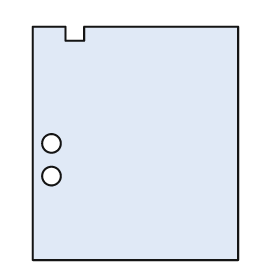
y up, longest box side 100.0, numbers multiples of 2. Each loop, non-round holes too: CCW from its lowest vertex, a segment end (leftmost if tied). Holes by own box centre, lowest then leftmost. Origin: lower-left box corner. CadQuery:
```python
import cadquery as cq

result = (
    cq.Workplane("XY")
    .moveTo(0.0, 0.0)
    .lineTo(88.0, 0.0)
    .lineTo(88.0, 100.0)
    .lineTo(22.0, 100.0)
    .lineTo(22.0, 94.0)
    .lineTo(14.0, 94.0)
    .lineTo(14.0, 100.0)
    .lineTo(0.0, 100.0)
    .close()
    .moveTo(8.0, 36.0)
    .circle(4.0)
    .moveTo(8.0, 50.0)
    .circle(4.0)
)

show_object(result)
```